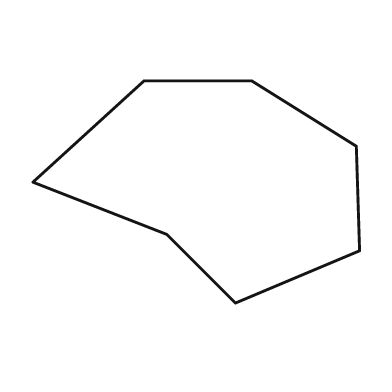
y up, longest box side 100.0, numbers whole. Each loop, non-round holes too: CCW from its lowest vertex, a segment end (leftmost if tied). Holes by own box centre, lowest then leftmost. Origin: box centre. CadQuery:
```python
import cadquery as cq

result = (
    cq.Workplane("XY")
    .moveTo(12.0, -34.0)
    .lineTo(50.0, -18.0)
    .lineTo(49.0, 14.0)
    .lineTo(17.0, 34.0)
    .lineTo(-16.0, 34.0)
    .lineTo(-50.0, 3.0)
    .lineTo(-9.0, -13.0)
    .close()
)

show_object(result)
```